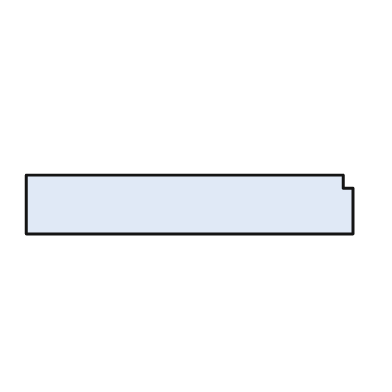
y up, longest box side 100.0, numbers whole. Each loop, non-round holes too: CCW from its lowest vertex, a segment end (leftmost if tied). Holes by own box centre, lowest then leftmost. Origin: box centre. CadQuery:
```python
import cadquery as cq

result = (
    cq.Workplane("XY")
    .moveTo(-50.0, -9.0)
    .lineTo(50.0, -9.0)
    .lineTo(50.0, 5.0)
    .lineTo(47.0, 5.0)
    .lineTo(47.0, 9.0)
    .lineTo(-50.0, 9.0)
    .close()
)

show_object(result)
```